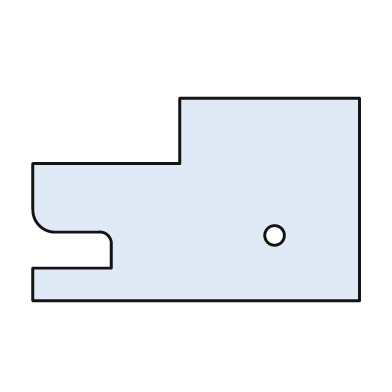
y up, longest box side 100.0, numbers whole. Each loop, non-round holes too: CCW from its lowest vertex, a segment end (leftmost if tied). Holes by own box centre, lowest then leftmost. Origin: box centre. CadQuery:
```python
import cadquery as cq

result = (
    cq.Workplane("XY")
    .moveTo(-50.0, -31.0)
    .lineTo(50.0, -31.0)
    .lineTo(50.0, 31.0)
    .lineTo(-5.0, 31.0)
    .lineTo(-5.0, 11.0)
    .lineTo(-50.0, 11.0)
    .lineTo(-50.0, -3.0)
    .threePointArc((-48.0, -8.0), (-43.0, -10.0))
    .lineTo(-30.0, -10.0)
    .threePointArc((-27.0, -11.0), (-26.0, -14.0))
    .lineTo(-26.0, -21.0)
    .lineTo(-50.0, -21.0)
    .close()
    .moveTo(24.0, -11.0)
    .circle(3.0)
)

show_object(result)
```